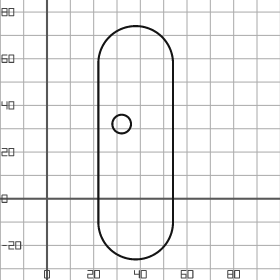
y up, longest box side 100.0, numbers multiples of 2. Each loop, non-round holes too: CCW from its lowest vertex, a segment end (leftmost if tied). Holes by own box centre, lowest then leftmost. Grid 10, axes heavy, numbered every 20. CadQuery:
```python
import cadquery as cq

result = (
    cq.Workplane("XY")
    .moveTo(22.0, -10.0)
    .threePointArc((38.0, -26.0), (54.0, -10.0))
    .lineTo(54.0, 58.0)
    .threePointArc((38.0, 74.0), (22.0, 58.0))
    .close()
    .moveTo(32.0, 32.0)
    .circle(4.0)
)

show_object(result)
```